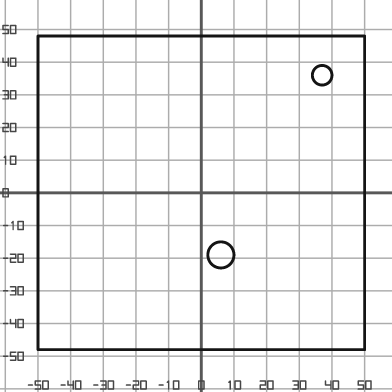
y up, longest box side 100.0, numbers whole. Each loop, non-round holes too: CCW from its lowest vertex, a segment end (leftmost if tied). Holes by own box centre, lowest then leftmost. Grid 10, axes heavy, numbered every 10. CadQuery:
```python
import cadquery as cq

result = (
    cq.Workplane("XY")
    .moveTo(-50.0, -48.0)
    .lineTo(50.0, -48.0)
    .lineTo(50.0, 48.0)
    .lineTo(-50.0, 48.0)
    .close()
    .moveTo(6.0, -19.0)
    .circle(4.0)
    .moveTo(37.0, 36.0)
    .circle(3.0)
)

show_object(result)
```